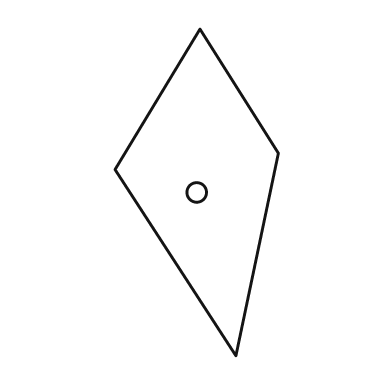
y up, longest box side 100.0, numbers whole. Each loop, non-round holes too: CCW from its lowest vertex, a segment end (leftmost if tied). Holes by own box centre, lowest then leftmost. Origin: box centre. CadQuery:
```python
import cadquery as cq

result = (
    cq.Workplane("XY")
    .moveTo(12.0, -50.0)
    .lineTo(25.0, 12.0)
    .lineTo(1.0, 50.0)
    .lineTo(-25.0, 7.0)
    .close()
    .moveTo(0.0, 0.0)
    .circle(3.0)
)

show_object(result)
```